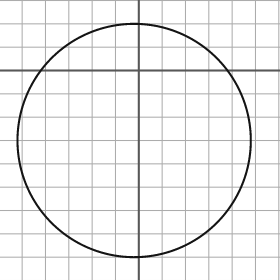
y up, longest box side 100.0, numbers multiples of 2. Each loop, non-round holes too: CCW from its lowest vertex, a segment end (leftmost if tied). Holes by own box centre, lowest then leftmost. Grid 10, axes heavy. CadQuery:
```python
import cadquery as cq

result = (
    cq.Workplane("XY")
    .moveTo(-2.0, -30.0)
    .circle(50.0)
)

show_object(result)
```